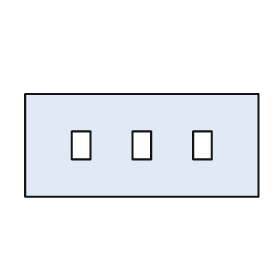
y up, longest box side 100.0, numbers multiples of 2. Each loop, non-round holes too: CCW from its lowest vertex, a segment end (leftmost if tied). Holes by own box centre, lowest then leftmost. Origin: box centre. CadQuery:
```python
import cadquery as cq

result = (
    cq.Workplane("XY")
    .moveTo(-50.0, -22.0)
    .lineTo(50.0, -22.0)
    .lineTo(50.0, 22.0)
    .lineTo(-50.0, 22.0)
    .close()
    .moveTo(-30.0, -6.0)
    .lineTo(-22.0, -6.0)
    .lineTo(-22.0, 6.0)
    .lineTo(-30.0, 6.0)
    .close()
    .moveTo(-4.0, -6.0)
    .lineTo(4.0, -6.0)
    .lineTo(4.0, 6.0)
    .lineTo(-4.0, 6.0)
    .close()
    .moveTo(22.0, -6.0)
    .lineTo(30.0, -6.0)
    .lineTo(30.0, 6.0)
    .lineTo(22.0, 6.0)
    .close()
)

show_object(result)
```